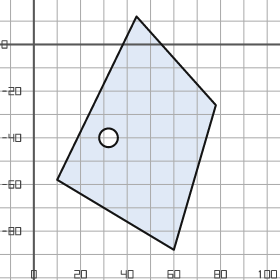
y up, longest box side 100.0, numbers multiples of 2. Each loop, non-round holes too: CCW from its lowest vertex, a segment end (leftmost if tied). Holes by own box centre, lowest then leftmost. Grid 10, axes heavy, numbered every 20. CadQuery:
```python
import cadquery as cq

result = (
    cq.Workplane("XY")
    .moveTo(60.0, -88.0)
    .lineTo(78.0, -26.0)
    .lineTo(44.0, 12.0)
    .lineTo(10.0, -58.0)
    .close()
    .moveTo(32.0, -40.0)
    .circle(4.0)
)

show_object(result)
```